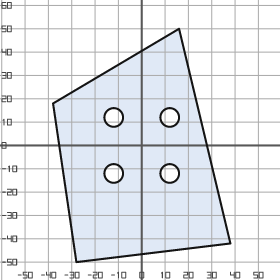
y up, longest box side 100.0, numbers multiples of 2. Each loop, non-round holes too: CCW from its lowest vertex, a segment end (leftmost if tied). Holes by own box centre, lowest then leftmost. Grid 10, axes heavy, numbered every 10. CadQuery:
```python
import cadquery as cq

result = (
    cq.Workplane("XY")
    .moveTo(-28.0, -50.0)
    .lineTo(38.0, -42.0)
    .lineTo(16.0, 50.0)
    .lineTo(-38.0, 18.0)
    .close()
    .moveTo(-12.0, -12.0)
    .circle(4.0)
    .moveTo(12.0, -12.0)
    .circle(4.0)
    .moveTo(-12.0, 12.0)
    .circle(4.0)
    .moveTo(12.0, 12.0)
    .circle(4.0)
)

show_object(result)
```